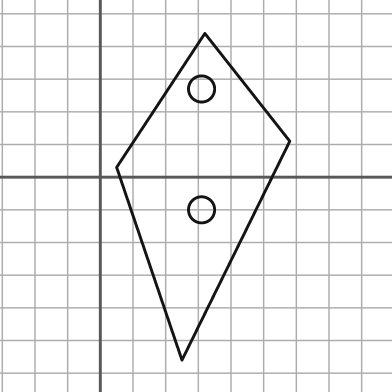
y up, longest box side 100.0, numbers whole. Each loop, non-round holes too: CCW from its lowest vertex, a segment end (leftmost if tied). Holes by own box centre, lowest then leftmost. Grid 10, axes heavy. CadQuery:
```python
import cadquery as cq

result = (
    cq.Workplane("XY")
    .moveTo(25.0, -56.0)
    .lineTo(58.0, 11.0)
    .lineTo(32.0, 44.0)
    .lineTo(5.0, 3.0)
    .close()
    .moveTo(31.0, -10.0)
    .circle(4.0)
    .moveTo(31.0, 27.0)
    .circle(4.0)
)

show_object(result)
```